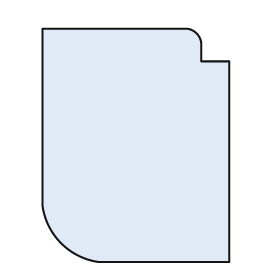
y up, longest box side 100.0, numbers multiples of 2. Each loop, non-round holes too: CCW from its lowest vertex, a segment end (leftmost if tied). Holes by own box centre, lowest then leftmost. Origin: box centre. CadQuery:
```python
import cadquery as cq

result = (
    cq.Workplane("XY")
    .moveTo(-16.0, -50.0)
    .lineTo(40.0, -50.0)
    .lineTo(40.0, 36.0)
    .lineTo(28.0, 36.0)
    .lineTo(28.0, 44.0)
    .threePointArc((26.0, 48.0), (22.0, 50.0))
    .lineTo(-40.0, 50.0)
    .lineTo(-40.0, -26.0)
    .threePointArc((-32.0, -42.0), (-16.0, -50.0))
    .close()
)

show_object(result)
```